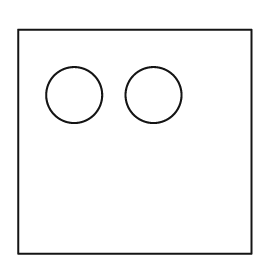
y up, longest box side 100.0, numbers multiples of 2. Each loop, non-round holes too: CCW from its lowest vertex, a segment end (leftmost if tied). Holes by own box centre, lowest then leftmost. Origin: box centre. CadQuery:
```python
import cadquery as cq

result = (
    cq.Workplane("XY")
    .moveTo(-50.0, -48.0)
    .lineTo(50.0, -48.0)
    .lineTo(50.0, 48.0)
    .lineTo(-50.0, 48.0)
    .close()
    .moveTo(-26.0, 20.0)
    .circle(12.0)
    .moveTo(8.0, 20.0)
    .circle(12.0)
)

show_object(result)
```